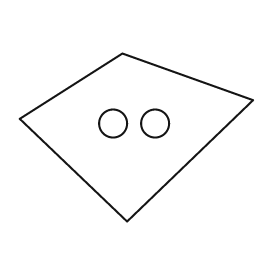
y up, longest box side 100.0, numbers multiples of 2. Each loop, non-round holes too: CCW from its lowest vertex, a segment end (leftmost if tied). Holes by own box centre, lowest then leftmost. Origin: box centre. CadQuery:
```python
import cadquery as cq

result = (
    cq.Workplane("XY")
    .moveTo(-4.0, -36.0)
    .lineTo(50.0, 16.0)
    .lineTo(-6.0, 36.0)
    .lineTo(-50.0, 8.0)
    .close()
    .moveTo(-10.0, 6.0)
    .circle(6.0)
    .moveTo(8.0, 6.0)
    .circle(6.0)
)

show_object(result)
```